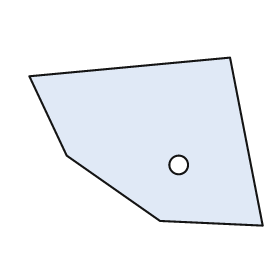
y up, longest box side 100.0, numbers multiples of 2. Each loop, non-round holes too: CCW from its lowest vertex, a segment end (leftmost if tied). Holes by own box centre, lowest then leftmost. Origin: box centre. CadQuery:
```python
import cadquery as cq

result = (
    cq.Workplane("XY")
    .moveTo(50.0, -36.0)
    .lineTo(36.0, 36.0)
    .lineTo(-50.0, 28.0)
    .lineTo(-34.0, -6.0)
    .lineTo(6.0, -34.0)
    .close()
    .moveTo(14.0, -10.0)
    .circle(4.0)
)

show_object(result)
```